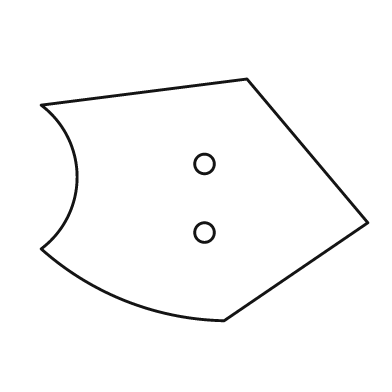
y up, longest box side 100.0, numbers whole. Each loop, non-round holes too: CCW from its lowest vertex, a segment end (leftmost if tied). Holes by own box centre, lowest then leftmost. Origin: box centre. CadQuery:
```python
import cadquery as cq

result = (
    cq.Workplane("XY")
    .moveTo(6.0, -37.0)
    .lineTo(50.0, -7.0)
    .lineTo(13.0, 37.0)
    .lineTo(-50.0, 29.0)
    .threePointArc((-39.0, 7.0), (-50.0, -15.0))
    .threePointArc((-24.0, -31.0), (6.0, -37.0))
    .close()
    .moveTo(0.0, -10.0)
    .circle(3.0)
    .moveTo(0.0, 11.0)
    .circle(3.0)
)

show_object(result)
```